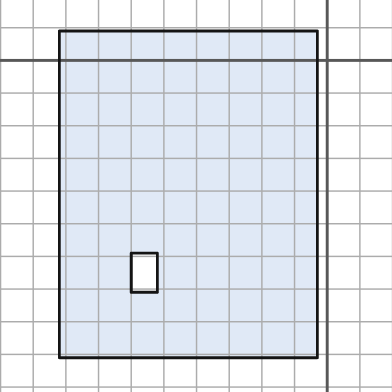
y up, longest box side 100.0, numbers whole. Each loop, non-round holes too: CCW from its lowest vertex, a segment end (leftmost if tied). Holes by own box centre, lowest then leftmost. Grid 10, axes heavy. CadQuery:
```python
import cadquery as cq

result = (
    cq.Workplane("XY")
    .moveTo(-82.0, -91.0)
    .lineTo(-3.0, -91.0)
    .lineTo(-3.0, 9.0)
    .lineTo(-82.0, 9.0)
    .close()
    .moveTo(-60.0, -71.0)
    .lineTo(-52.0, -71.0)
    .lineTo(-52.0, -59.0)
    .lineTo(-60.0, -59.0)
    .close()
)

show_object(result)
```